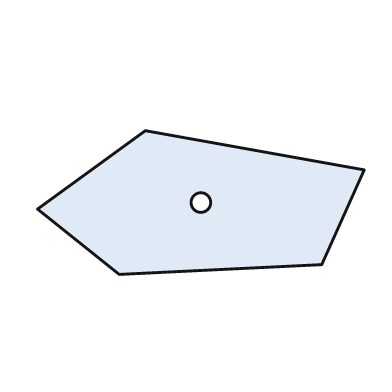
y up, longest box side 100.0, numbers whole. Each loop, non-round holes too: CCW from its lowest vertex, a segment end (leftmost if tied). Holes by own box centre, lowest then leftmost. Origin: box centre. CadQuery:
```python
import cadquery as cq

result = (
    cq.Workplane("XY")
    .moveTo(-25.0, -22.0)
    .lineTo(37.0, -19.0)
    .lineTo(50.0, 10.0)
    .lineTo(-17.0, 22.0)
    .lineTo(-50.0, -2.0)
    .close()
    .moveTo(0.0, 0.0)
    .circle(3.0)
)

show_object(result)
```